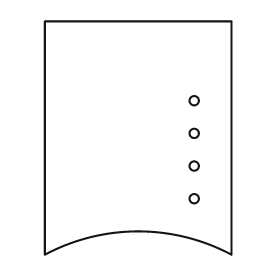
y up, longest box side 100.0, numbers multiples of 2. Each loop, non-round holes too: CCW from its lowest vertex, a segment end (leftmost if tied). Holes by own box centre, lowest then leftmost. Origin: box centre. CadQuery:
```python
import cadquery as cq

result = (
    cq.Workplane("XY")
    .moveTo(-40.0, -50.0)
    .threePointArc((0.0, -40.0), (40.0, -50.0))
    .lineTo(40.0, 50.0)
    .lineTo(-40.0, 50.0)
    .close()
    .moveTo(24.0, -26.0)
    .circle(2.0)
    .moveTo(24.0, -12.0)
    .circle(2.0)
    .moveTo(24.0, 2.0)
    .circle(2.0)
    .moveTo(24.0, 16.0)
    .circle(2.0)
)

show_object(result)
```